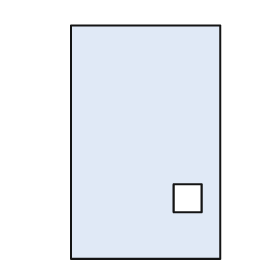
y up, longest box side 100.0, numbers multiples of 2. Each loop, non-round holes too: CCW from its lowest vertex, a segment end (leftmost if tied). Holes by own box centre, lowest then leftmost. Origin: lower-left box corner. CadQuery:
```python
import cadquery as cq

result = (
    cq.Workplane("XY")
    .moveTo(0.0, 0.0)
    .lineTo(64.0, 0.0)
    .lineTo(64.0, 100.0)
    .lineTo(0.0, 100.0)
    .close()
    .moveTo(44.0, 20.0)
    .lineTo(56.0, 20.0)
    .lineTo(56.0, 32.0)
    .lineTo(44.0, 32.0)
    .close()
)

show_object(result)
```